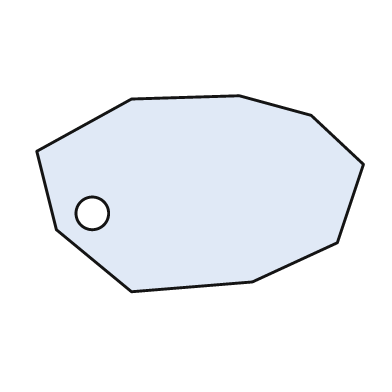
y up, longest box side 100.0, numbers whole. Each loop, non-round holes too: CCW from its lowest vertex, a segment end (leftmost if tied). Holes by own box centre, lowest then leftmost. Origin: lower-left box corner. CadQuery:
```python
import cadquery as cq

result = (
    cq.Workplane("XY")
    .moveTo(29.0, 0.0)
    .lineTo(66.0, 3.0)
    .lineTo(92.0, 15.0)
    .lineTo(100.0, 39.0)
    .lineTo(84.0, 54.0)
    .lineTo(62.0, 60.0)
    .lineTo(29.0, 59.0)
    .lineTo(0.0, 43.0)
    .lineTo(6.0, 19.0)
    .close()
    .moveTo(17.0, 24.0)
    .circle(5.0)
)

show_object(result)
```